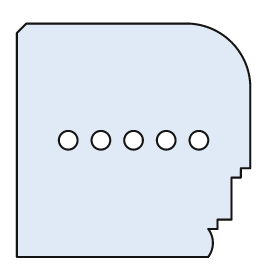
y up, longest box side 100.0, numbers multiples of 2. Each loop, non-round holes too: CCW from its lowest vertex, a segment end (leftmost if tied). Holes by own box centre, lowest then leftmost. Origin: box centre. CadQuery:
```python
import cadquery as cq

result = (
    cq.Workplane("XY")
    .moveTo(-50.0, -50.0)
    .lineTo(32.0, -50.0)
    .threePointArc((34.0, -44.0), (32.0, -38.0))
    .lineTo(36.0, -38.0)
    .lineTo(36.0, -34.0)
    .lineTo(42.0, -34.0)
    .lineTo(42.0, -16.0)
    .lineTo(46.0, -16.0)
    .lineTo(46.0, -12.0)
    .lineTo(50.0, -12.0)
    .lineTo(50.0, 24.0)
    .threePointArc((42.0, 42.0), (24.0, 50.0))
    .lineTo(-46.0, 50.0)
    .lineTo(-50.0, 46.0)
    .close()
    .moveTo(-28.0, 0.0)
    .circle(4.0)
    .moveTo(-14.0, 0.0)
    .circle(4.0)
    .moveTo(0.0, 0.0)
    .circle(4.0)
    .moveTo(14.0, 0.0)
    .circle(4.0)
    .moveTo(28.0, 0.0)
    .circle(4.0)
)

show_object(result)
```